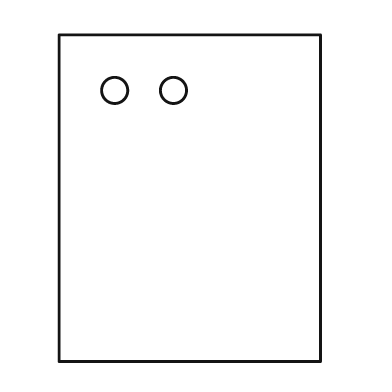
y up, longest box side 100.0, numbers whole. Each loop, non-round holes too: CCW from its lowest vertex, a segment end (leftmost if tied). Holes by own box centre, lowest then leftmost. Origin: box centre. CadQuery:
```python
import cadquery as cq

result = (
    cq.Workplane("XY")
    .moveTo(-40.0, -50.0)
    .lineTo(40.0, -50.0)
    .lineTo(40.0, 50.0)
    .lineTo(-40.0, 50.0)
    .close()
    .moveTo(-23.0, 33.0)
    .circle(4.0)
    .moveTo(-5.0, 33.0)
    .circle(4.0)
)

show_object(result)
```